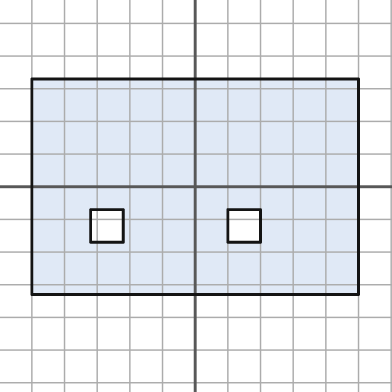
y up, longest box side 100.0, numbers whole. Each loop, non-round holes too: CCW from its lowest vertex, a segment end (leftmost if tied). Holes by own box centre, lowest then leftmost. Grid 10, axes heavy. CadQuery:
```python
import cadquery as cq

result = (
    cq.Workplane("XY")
    .moveTo(-50.0, -33.0)
    .lineTo(50.0, -33.0)
    .lineTo(50.0, 33.0)
    .lineTo(-50.0, 33.0)
    .close()
    .moveTo(-32.0, -17.0)
    .lineTo(-22.0, -17.0)
    .lineTo(-22.0, -7.0)
    .lineTo(-32.0, -7.0)
    .close()
    .moveTo(10.0, -17.0)
    .lineTo(20.0, -17.0)
    .lineTo(20.0, -7.0)
    .lineTo(10.0, -7.0)
    .close()
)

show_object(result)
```